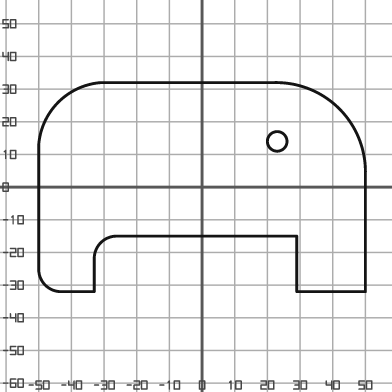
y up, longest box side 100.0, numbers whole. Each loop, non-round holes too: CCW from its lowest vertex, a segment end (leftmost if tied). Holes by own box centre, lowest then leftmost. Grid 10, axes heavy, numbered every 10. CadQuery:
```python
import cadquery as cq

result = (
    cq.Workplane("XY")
    .moveTo(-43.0, -32.0)
    .lineTo(-33.0, -32.0)
    .lineTo(-33.0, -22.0)
    .threePointArc((-31.0, -17.0), (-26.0, -15.0))
    .lineTo(29.0, -15.0)
    .lineTo(29.0, -32.0)
    .lineTo(50.0, -32.0)
    .lineTo(50.0, 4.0)
    .threePointArc((42.0, 24.0), (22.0, 32.0))
    .lineTo(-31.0, 32.0)
    .threePointArc((-44.0, 26.0), (-50.0, 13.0))
    .lineTo(-50.0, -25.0)
    .threePointArc((-48.0, -30.0), (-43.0, -32.0))
    .close()
    .moveTo(23.0, 14.0)
    .circle(3.0)
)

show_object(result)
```